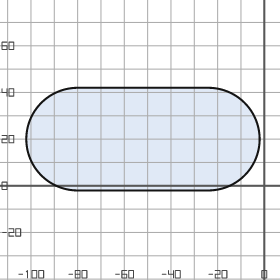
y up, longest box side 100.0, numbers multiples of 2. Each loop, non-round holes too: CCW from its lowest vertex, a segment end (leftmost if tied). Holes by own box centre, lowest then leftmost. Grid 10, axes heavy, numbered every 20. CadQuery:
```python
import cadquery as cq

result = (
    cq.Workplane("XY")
    .moveTo(-80.0, -2.0)
    .lineTo(-24.0, -2.0)
    .threePointArc((-2.0, 20.0), (-24.0, 42.0))
    .lineTo(-80.0, 42.0)
    .threePointArc((-102.0, 20.0), (-80.0, -2.0))
    .close()
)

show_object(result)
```